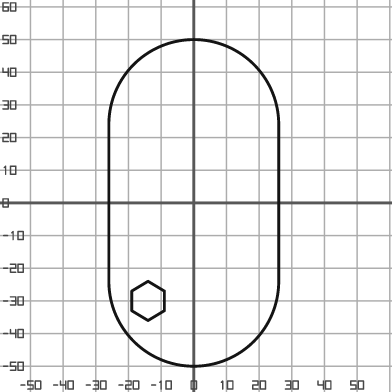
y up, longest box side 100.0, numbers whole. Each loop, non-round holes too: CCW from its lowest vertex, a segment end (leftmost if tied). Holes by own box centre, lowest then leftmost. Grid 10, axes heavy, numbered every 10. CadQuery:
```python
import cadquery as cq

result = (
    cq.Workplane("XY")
    .moveTo(-26.0, -24.0)
    .threePointArc((0.0, -50.0), (26.0, -24.0))
    .lineTo(26.0, 24.0)
    .threePointArc((0.0, 50.0), (-26.0, 24.0))
    .close()
    .moveTo(-14.0, -36.0)
    .lineTo(-9.0, -33.0)
    .lineTo(-9.0, -27.0)
    .lineTo(-14.0, -24.0)
    .lineTo(-19.0, -27.0)
    .lineTo(-19.0, -33.0)
    .close()
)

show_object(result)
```